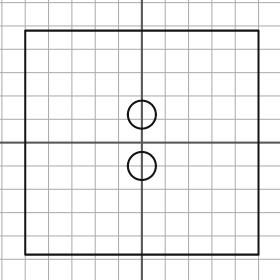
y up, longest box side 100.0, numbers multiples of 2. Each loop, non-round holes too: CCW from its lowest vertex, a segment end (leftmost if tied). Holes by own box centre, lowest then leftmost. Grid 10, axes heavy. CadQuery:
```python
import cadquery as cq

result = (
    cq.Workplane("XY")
    .moveTo(-50.0, -48.0)
    .lineTo(50.0, -48.0)
    .lineTo(50.0, 48.0)
    .lineTo(-50.0, 48.0)
    .close()
    .moveTo(0.0, -10.0)
    .circle(6.0)
    .moveTo(0.0, 12.0)
    .circle(6.0)
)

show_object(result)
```